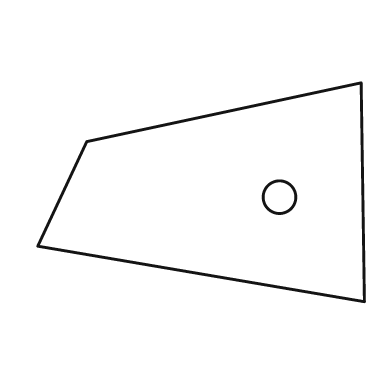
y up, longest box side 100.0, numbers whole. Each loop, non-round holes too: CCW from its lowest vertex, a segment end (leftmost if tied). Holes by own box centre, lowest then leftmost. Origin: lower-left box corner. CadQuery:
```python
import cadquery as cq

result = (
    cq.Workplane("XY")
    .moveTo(100.0, 0.0)
    .lineTo(99.0, 67.0)
    .lineTo(15.0, 49.0)
    .lineTo(0.0, 17.0)
    .close()
    .moveTo(74.0, 32.0)
    .circle(5.0)
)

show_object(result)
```